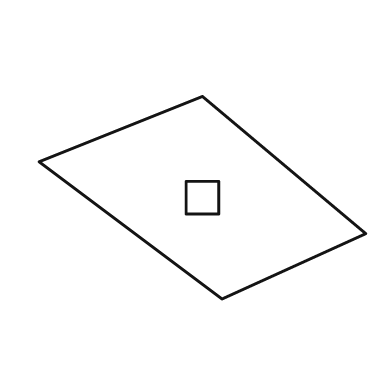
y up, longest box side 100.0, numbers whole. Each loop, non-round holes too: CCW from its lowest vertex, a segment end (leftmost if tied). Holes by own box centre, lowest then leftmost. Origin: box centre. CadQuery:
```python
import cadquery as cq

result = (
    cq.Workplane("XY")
    .moveTo(6.0, -31.0)
    .lineTo(50.0, -11.0)
    .lineTo(0.0, 31.0)
    .lineTo(-50.0, 11.0)
    .close()
    .moveTo(-5.0, -5.0)
    .lineTo(5.0, -5.0)
    .lineTo(5.0, 5.0)
    .lineTo(-5.0, 5.0)
    .close()
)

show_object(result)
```